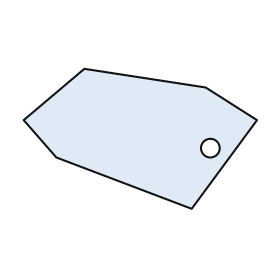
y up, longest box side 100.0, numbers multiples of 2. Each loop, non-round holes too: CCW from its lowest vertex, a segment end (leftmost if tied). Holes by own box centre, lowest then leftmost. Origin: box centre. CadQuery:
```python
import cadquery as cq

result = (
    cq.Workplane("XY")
    .moveTo(22.0, -30.0)
    .lineTo(50.0, 8.0)
    .lineTo(28.0, 22.0)
    .lineTo(-24.0, 30.0)
    .lineTo(-50.0, 8.0)
    .lineTo(-36.0, -8.0)
    .close()
    .moveTo(30.0, -4.0)
    .circle(4.0)
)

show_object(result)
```